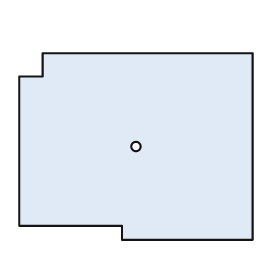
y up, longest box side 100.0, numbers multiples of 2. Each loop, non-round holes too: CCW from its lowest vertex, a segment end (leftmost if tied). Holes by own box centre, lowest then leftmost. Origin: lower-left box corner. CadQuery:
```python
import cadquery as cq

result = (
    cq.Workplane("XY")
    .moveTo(44.0, 0.0)
    .lineTo(100.0, 0.0)
    .lineTo(100.0, 80.0)
    .lineTo(10.0, 80.0)
    .lineTo(10.0, 70.0)
    .lineTo(0.0, 70.0)
    .lineTo(0.0, 6.0)
    .lineTo(44.0, 6.0)
    .close()
    .moveTo(50.0, 40.0)
    .circle(2.0)
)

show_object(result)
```